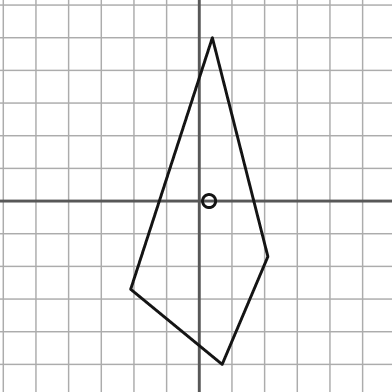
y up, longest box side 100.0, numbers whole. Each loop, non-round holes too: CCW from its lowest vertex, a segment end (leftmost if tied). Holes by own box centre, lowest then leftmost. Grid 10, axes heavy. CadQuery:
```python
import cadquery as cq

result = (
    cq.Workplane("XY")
    .moveTo(7.0, -50.0)
    .lineTo(21.0, -17.0)
    .lineTo(4.0, 50.0)
    .lineTo(-21.0, -27.0)
    .close()
    .moveTo(3.0, 0.0)
    .circle(2.0)
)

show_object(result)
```